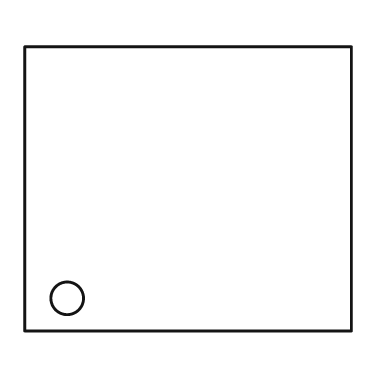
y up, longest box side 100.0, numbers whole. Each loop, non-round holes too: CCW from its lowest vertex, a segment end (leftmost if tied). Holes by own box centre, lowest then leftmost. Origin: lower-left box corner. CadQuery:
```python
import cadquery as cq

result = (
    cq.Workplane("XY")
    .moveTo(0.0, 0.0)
    .lineTo(100.0, 0.0)
    .lineTo(100.0, 87.0)
    .lineTo(0.0, 87.0)
    .close()
    .moveTo(13.0, 10.0)
    .circle(5.0)
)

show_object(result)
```